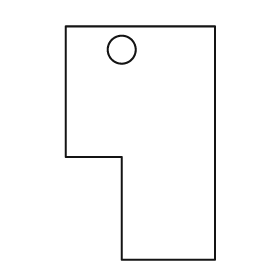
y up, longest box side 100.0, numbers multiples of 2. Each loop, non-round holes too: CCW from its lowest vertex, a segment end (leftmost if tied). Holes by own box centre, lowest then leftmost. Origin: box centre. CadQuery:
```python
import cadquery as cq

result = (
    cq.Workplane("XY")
    .moveTo(-8.0, -50.0)
    .lineTo(32.0, -50.0)
    .lineTo(32.0, 50.0)
    .lineTo(-32.0, 50.0)
    .lineTo(-32.0, -6.0)
    .lineTo(-8.0, -6.0)
    .close()
    .moveTo(-8.0, 40.0)
    .circle(6.0)
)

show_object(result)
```